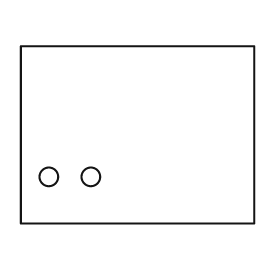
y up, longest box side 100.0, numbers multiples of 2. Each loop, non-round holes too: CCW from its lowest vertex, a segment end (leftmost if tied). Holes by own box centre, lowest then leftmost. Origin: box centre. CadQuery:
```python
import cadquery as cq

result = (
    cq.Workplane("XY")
    .moveTo(-50.0, -38.0)
    .lineTo(50.0, -38.0)
    .lineTo(50.0, 38.0)
    .lineTo(-50.0, 38.0)
    .close()
    .moveTo(-38.0, -18.0)
    .circle(4.0)
    .moveTo(-20.0, -18.0)
    .circle(4.0)
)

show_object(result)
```